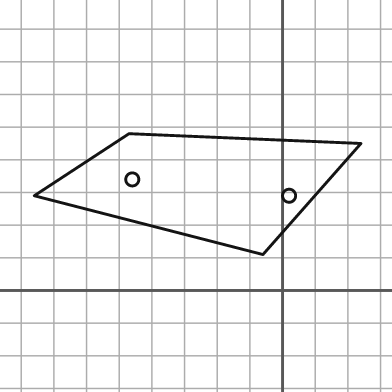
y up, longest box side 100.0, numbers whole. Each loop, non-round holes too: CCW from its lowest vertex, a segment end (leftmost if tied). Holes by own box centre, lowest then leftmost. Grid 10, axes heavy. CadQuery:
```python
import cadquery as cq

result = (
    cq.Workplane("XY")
    .moveTo(-6.0, 11.0)
    .lineTo(24.0, 45.0)
    .lineTo(-47.0, 48.0)
    .lineTo(-76.0, 29.0)
    .close()
    .moveTo(2.0, 29.0)
    .circle(2.0)
    .moveTo(-46.0, 34.0)
    .circle(2.0)
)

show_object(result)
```